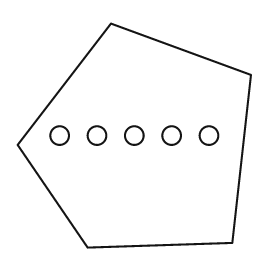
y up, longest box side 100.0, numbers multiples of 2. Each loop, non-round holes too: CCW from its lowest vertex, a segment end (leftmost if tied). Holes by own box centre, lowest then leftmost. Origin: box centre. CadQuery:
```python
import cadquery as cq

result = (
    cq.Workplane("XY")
    .moveTo(-20.0, -48.0)
    .lineTo(42.0, -46.0)
    .lineTo(50.0, 26.0)
    .lineTo(-10.0, 48.0)
    .lineTo(-50.0, -4.0)
    .close()
    .moveTo(-32.0, 0.0)
    .circle(4.0)
    .moveTo(-16.0, 0.0)
    .circle(4.0)
    .moveTo(0.0, 0.0)
    .circle(4.0)
    .moveTo(16.0, 0.0)
    .circle(4.0)
    .moveTo(32.0, 0.0)
    .circle(4.0)
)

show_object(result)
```